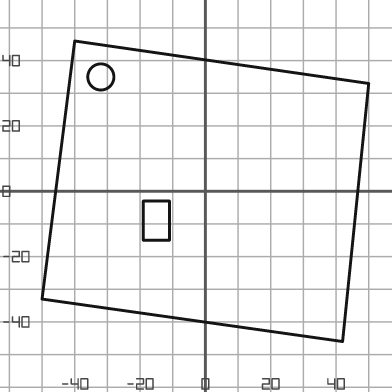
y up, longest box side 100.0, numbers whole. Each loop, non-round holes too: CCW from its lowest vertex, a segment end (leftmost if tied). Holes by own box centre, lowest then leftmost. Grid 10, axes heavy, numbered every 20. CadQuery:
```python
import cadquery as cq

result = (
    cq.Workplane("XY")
    .moveTo(42.0, -46.0)
    .lineTo(50.0, 33.0)
    .lineTo(-40.0, 46.0)
    .lineTo(-50.0, -33.0)
    .close()
    .moveTo(-19.0, -15.0)
    .lineTo(-11.0, -15.0)
    .lineTo(-11.0, -3.0)
    .lineTo(-19.0, -3.0)
    .close()
    .moveTo(-32.0, 35.0)
    .circle(4.0)
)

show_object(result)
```